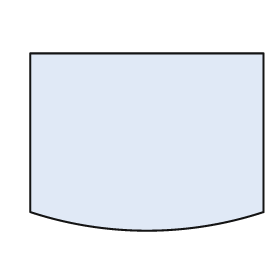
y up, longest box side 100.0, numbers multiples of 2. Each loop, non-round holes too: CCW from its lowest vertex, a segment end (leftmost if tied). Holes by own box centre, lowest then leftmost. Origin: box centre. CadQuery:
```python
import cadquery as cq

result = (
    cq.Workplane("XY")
    .moveTo(-50.0, -30.0)
    .threePointArc((0.0, -38.0), (50.0, -30.0))
    .lineTo(50.0, 38.0)
    .lineTo(-50.0, 38.0)
    .close()
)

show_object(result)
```